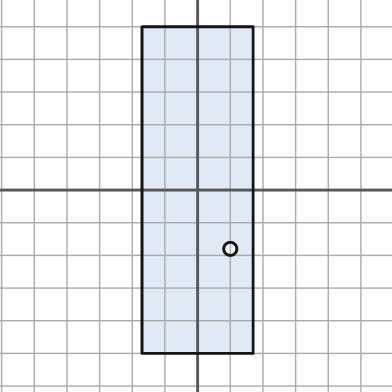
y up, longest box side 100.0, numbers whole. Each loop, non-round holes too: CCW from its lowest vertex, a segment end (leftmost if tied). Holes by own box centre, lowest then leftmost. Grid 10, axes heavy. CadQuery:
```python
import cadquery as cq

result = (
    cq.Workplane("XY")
    .moveTo(-17.0, -50.0)
    .lineTo(17.0, -50.0)
    .lineTo(17.0, 50.0)
    .lineTo(-17.0, 50.0)
    .close()
    .moveTo(10.0, -18.0)
    .circle(2.0)
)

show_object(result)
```